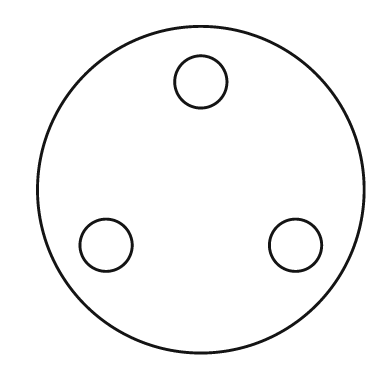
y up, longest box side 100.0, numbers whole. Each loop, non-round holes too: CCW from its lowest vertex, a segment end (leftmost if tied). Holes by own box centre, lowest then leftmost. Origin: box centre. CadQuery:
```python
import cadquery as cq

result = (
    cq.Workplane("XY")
    .moveTo(0.0, 0.0)
    .circle(50.0)
    .moveTo(-29.0, -17.0)
    .circle(8.0)
    .moveTo(29.0, -17.0)
    .circle(8.0)
    .moveTo(0.0, 33.0)
    .circle(8.0)
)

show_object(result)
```